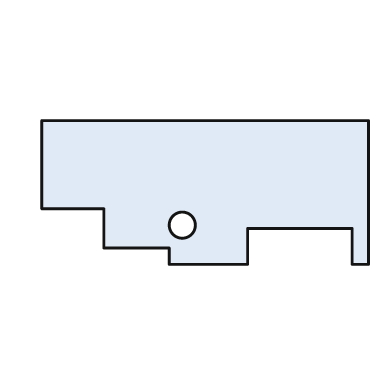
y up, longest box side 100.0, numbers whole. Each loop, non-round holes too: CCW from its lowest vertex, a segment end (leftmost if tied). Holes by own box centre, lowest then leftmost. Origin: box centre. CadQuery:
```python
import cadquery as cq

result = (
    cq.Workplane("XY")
    .moveTo(-11.0, -22.0)
    .lineTo(13.0, -22.0)
    .lineTo(13.0, -11.0)
    .lineTo(45.0, -11.0)
    .lineTo(45.0, -22.0)
    .lineTo(50.0, -22.0)
    .lineTo(50.0, 22.0)
    .lineTo(-50.0, 22.0)
    .lineTo(-50.0, -5.0)
    .lineTo(-31.0, -5.0)
    .lineTo(-31.0, -17.0)
    .lineTo(-11.0, -17.0)
    .close()
    .moveTo(-7.0, -10.0)
    .circle(4.0)
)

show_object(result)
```